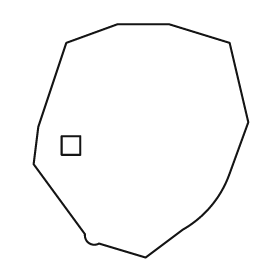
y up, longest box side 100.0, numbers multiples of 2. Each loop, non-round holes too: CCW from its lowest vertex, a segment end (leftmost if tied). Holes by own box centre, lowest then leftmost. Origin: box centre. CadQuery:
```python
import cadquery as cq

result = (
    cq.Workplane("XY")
    .moveTo(2.0, -50.0)
    .lineTo(18.0, -38.0)
    .threePointArc((30.0, -28.0), (38.0, -14.0))
    .lineTo(46.0, 8.0)
    .lineTo(38.0, 42.0)
    .lineTo(12.0, 50.0)
    .lineTo(-10.0, 50.0)
    .lineTo(-32.0, 42.0)
    .lineTo(-44.0, 6.0)
    .lineTo(-46.0, -10.0)
    .lineTo(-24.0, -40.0)
    .threePointArc((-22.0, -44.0), (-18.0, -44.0))
    .close()
    .moveTo(-34.0, -6.0)
    .lineTo(-26.0, -6.0)
    .lineTo(-26.0, 2.0)
    .lineTo(-34.0, 2.0)
    .close()
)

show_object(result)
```